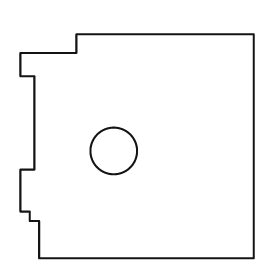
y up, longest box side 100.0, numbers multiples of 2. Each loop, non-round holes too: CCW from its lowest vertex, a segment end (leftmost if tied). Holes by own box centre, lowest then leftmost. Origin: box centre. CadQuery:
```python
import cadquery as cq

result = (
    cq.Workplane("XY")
    .moveTo(-42.0, -48.0)
    .lineTo(50.0, -48.0)
    .lineTo(50.0, 48.0)
    .lineTo(-26.0, 48.0)
    .lineTo(-26.0, 40.0)
    .lineTo(-50.0, 40.0)
    .lineTo(-50.0, 30.0)
    .lineTo(-44.0, 30.0)
    .lineTo(-44.0, -10.0)
    .lineTo(-50.0, -10.0)
    .lineTo(-50.0, -28.0)
    .lineTo(-46.0, -28.0)
    .lineTo(-46.0, -32.0)
    .lineTo(-42.0, -32.0)
    .close()
    .moveTo(-10.0, -2.0)
    .circle(10.0)
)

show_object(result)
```